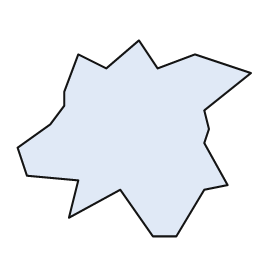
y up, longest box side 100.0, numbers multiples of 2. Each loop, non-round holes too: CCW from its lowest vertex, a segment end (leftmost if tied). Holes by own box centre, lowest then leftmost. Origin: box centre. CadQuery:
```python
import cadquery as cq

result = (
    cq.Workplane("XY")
    .moveTo(8.0, -42.0)
    .lineTo(18.0, -42.0)
    .lineTo(30.0, -22.0)
    .lineTo(40.0, -20.0)
    .lineTo(30.0, -2.0)
    .lineTo(32.0, 4.0)
    .lineTo(30.0, 12.0)
    .lineTo(50.0, 28.0)
    .lineTo(26.0, 36.0)
    .lineTo(10.0, 30.0)
    .lineTo(2.0, 42.0)
    .lineTo(-12.0, 30.0)
    .lineTo(-24.0, 36.0)
    .lineTo(-30.0, 20.0)
    .lineTo(-30.0, 14.0)
    .lineTo(-36.0, 6.0)
    .lineTo(-50.0, -4.0)
    .lineTo(-46.0, -16.0)
    .lineTo(-24.0, -18.0)
    .lineTo(-28.0, -34.0)
    .lineTo(-6.0, -22.0)
    .close()
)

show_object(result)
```